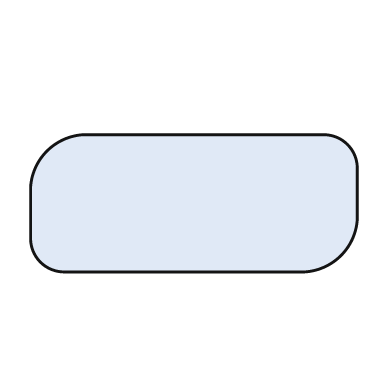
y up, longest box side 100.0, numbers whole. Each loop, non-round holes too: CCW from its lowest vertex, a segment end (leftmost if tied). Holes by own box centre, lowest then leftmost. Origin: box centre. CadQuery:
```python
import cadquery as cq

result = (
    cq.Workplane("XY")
    .moveTo(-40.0, -21.0)
    .lineTo(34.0, -21.0)
    .threePointArc((45.0, -16.0), (50.0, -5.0))
    .lineTo(50.0, 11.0)
    .threePointArc((47.0, 18.0), (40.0, 21.0))
    .lineTo(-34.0, 21.0)
    .threePointArc((-45.0, 16.0), (-50.0, 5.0))
    .lineTo(-50.0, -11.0)
    .threePointArc((-47.0, -18.0), (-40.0, -21.0))
    .close()
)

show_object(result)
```